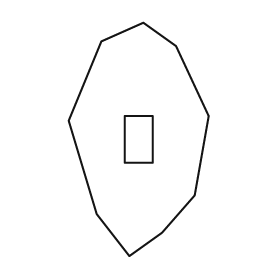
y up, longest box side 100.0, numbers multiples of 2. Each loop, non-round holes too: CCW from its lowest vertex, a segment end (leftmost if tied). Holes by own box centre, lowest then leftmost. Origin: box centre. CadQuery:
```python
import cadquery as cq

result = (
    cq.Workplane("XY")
    .moveTo(-4.0, -50.0)
    .lineTo(10.0, -40.0)
    .lineTo(24.0, -24.0)
    .lineTo(30.0, 10.0)
    .lineTo(16.0, 40.0)
    .lineTo(2.0, 50.0)
    .lineTo(-16.0, 42.0)
    .lineTo(-30.0, 8.0)
    .lineTo(-18.0, -32.0)
    .close()
    .moveTo(-6.0, -10.0)
    .lineTo(6.0, -10.0)
    .lineTo(6.0, 10.0)
    .lineTo(-6.0, 10.0)
    .close()
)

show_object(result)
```